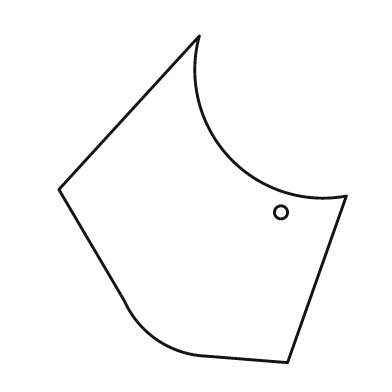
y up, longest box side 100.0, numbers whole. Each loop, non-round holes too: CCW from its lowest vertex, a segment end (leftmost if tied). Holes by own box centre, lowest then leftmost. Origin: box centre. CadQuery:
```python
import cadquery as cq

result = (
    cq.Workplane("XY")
    .moveTo(26.0, -50.0)
    .lineTo(44.0, 1.0)
    .threePointArc((8.0, 13.0), (-1.0, 50.0))
    .lineTo(-44.0, 3.0)
    .lineTo(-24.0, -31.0)
    .threePointArc((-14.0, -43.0), (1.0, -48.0))
    .close()
    .moveTo(24.0, -4.0)
    .circle(2.0)
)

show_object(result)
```